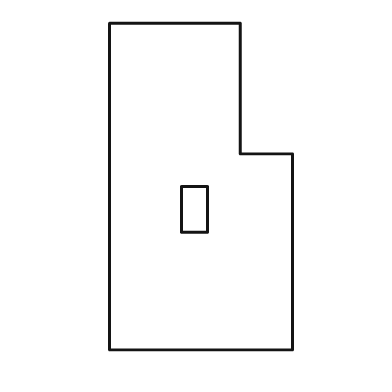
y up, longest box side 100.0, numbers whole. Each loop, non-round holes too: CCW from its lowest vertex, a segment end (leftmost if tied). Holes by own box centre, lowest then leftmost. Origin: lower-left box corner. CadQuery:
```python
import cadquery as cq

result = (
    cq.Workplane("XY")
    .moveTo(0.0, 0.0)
    .lineTo(56.0, 0.0)
    .lineTo(56.0, 60.0)
    .lineTo(40.0, 60.0)
    .lineTo(40.0, 100.0)
    .lineTo(0.0, 100.0)
    .close()
    .moveTo(22.0, 36.0)
    .lineTo(30.0, 36.0)
    .lineTo(30.0, 50.0)
    .lineTo(22.0, 50.0)
    .close()
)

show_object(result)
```